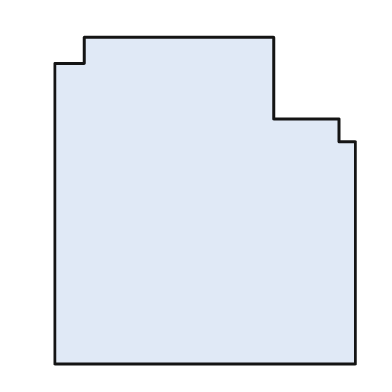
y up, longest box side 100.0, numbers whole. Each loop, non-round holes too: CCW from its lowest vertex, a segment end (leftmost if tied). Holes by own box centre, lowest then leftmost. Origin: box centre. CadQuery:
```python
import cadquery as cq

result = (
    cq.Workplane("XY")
    .moveTo(-46.0, -50.0)
    .lineTo(46.0, -50.0)
    .lineTo(46.0, 18.0)
    .lineTo(41.0, 18.0)
    .lineTo(41.0, 25.0)
    .lineTo(21.0, 25.0)
    .lineTo(21.0, 50.0)
    .lineTo(-37.0, 50.0)
    .lineTo(-37.0, 42.0)
    .lineTo(-46.0, 42.0)
    .close()
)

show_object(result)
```